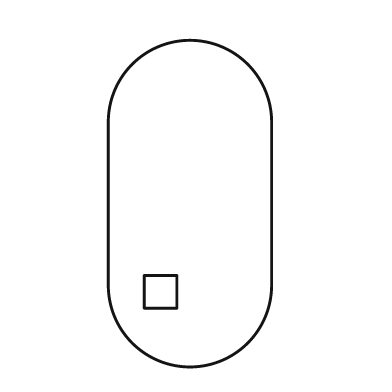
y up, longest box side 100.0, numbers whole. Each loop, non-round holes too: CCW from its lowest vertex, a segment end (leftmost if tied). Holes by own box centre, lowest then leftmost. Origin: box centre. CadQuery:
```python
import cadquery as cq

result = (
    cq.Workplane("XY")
    .moveTo(-25.0, -25.0)
    .threePointArc((0.0, -50.0), (25.0, -25.0))
    .lineTo(25.0, 25.0)
    .threePointArc((0.0, 50.0), (-25.0, 25.0))
    .close()
    .moveTo(-14.0, -32.0)
    .lineTo(-4.0, -32.0)
    .lineTo(-4.0, -22.0)
    .lineTo(-14.0, -22.0)
    .close()
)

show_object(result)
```